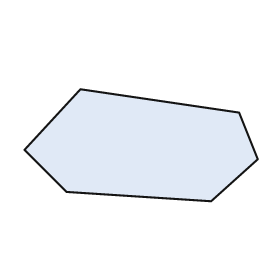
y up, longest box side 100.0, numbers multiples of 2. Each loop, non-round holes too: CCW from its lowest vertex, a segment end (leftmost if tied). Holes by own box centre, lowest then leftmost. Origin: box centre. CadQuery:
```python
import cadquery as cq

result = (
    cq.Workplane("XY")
    .moveTo(30.0, -24.0)
    .lineTo(50.0, -6.0)
    .lineTo(42.0, 14.0)
    .lineTo(-26.0, 24.0)
    .lineTo(-50.0, -2.0)
    .lineTo(-32.0, -20.0)
    .close()
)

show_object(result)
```